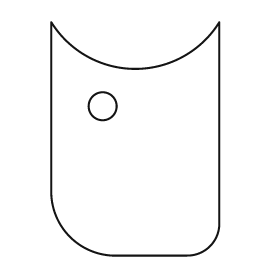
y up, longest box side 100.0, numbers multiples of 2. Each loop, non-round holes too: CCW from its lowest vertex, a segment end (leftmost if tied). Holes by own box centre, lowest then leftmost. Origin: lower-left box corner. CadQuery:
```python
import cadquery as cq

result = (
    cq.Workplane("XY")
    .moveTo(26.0, 0.0)
    .lineTo(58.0, 0.0)
    .threePointArc((68.0, 4.0), (72.0, 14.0))
    .lineTo(72.0, 100.0)
    .threePointArc((36.0, 80.0), (0.0, 100.0))
    .lineTo(0.0, 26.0)
    .threePointArc((8.0, 8.0), (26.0, 0.0))
    .close()
    .moveTo(22.0, 64.0)
    .circle(6.0)
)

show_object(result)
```